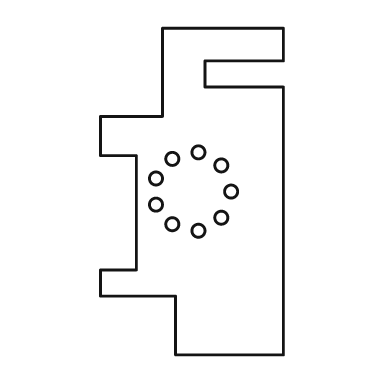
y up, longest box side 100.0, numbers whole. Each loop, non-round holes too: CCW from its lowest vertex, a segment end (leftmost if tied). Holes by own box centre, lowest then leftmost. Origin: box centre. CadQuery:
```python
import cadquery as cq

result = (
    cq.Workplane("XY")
    .moveTo(-5.0, -50.0)
    .lineTo(28.0, -50.0)
    .lineTo(28.0, 32.0)
    .lineTo(4.0, 32.0)
    .lineTo(4.0, 40.0)
    .lineTo(28.0, 40.0)
    .lineTo(28.0, 50.0)
    .lineTo(-9.0, 50.0)
    .lineTo(-9.0, 23.0)
    .lineTo(-28.0, 23.0)
    .lineTo(-28.0, 11.0)
    .lineTo(-17.0, 11.0)
    .lineTo(-17.0, -24.0)
    .lineTo(-28.0, -24.0)
    .lineTo(-28.0, -32.0)
    .lineTo(-5.0, -32.0)
    .close()
    .moveTo(2.0, -12.0)
    .circle(2.0)
    .moveTo(-6.0, -10.0)
    .circle(2.0)
    .moveTo(9.0, -8.0)
    .circle(2.0)
    .moveTo(-11.0, -4.0)
    .circle(2.0)
    .moveTo(12.0, 0.0)
    .circle(2.0)
    .moveTo(-11.0, 4.0)
    .circle(2.0)
    .moveTo(9.0, 8.0)
    .circle(2.0)
    .moveTo(-6.0, 10.0)
    .circle(2.0)
    .moveTo(2.0, 12.0)
    .circle(2.0)
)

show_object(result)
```